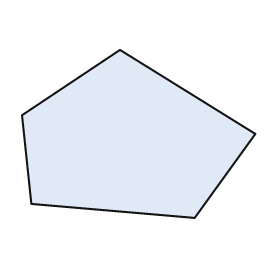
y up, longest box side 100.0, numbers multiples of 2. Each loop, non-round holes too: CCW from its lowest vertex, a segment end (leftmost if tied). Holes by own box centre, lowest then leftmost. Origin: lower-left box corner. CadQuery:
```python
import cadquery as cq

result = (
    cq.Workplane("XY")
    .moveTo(74.0, 0.0)
    .lineTo(100.0, 36.0)
    .lineTo(42.0, 72.0)
    .lineTo(0.0, 44.0)
    .lineTo(4.0, 6.0)
    .close()
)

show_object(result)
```